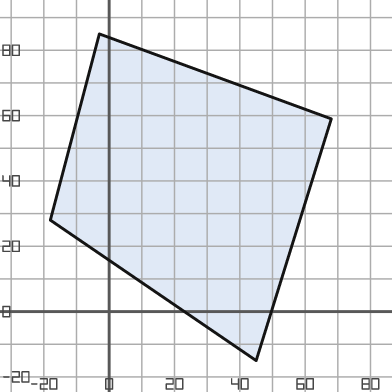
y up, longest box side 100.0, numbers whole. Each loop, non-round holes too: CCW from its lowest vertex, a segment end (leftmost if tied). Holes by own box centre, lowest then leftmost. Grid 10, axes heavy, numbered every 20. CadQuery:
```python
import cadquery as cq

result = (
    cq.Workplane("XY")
    .moveTo(45.0, -15.0)
    .lineTo(68.0, 59.0)
    .lineTo(-3.0, 85.0)
    .lineTo(-18.0, 28.0)
    .close()
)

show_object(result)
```